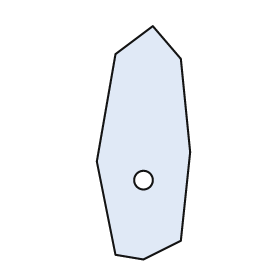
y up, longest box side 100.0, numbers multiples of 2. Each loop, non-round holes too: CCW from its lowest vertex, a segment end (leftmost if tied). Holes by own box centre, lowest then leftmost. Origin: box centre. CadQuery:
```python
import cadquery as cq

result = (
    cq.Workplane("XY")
    .moveTo(0.0, -50.0)
    .lineTo(16.0, -42.0)
    .lineTo(20.0, -4.0)
    .lineTo(16.0, 36.0)
    .lineTo(4.0, 50.0)
    .lineTo(-12.0, 38.0)
    .lineTo(-20.0, -8.0)
    .lineTo(-12.0, -48.0)
    .close()
    .moveTo(0.0, -16.0)
    .circle(4.0)
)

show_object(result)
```